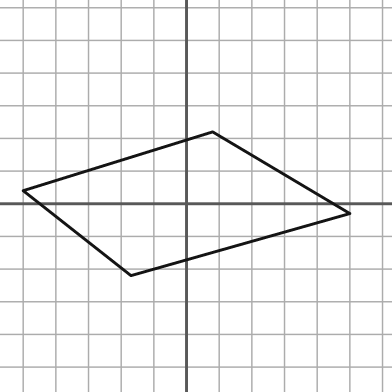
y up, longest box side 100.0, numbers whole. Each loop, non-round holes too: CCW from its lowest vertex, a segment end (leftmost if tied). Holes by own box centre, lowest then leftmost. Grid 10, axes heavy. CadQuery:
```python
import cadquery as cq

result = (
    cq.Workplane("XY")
    .moveTo(-17.0, -22.0)
    .lineTo(50.0, -3.0)
    .lineTo(8.0, 22.0)
    .lineTo(-50.0, 4.0)
    .close()
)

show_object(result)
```